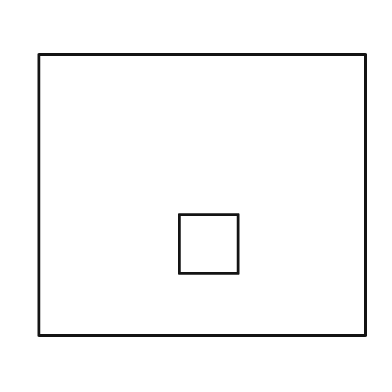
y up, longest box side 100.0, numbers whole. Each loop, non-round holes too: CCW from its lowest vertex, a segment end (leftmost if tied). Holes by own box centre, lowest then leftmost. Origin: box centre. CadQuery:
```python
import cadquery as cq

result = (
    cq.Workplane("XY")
    .moveTo(-50.0, -43.0)
    .lineTo(50.0, -43.0)
    .lineTo(50.0, 43.0)
    .lineTo(-50.0, 43.0)
    .close()
    .moveTo(-7.0, -24.0)
    .lineTo(11.0, -24.0)
    .lineTo(11.0, -6.0)
    .lineTo(-7.0, -6.0)
    .close()
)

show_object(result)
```